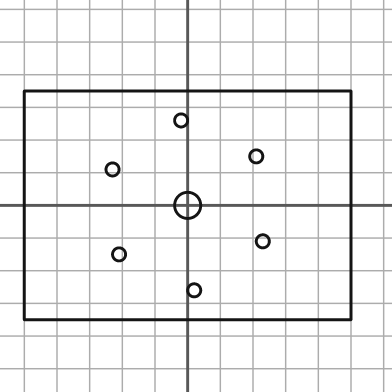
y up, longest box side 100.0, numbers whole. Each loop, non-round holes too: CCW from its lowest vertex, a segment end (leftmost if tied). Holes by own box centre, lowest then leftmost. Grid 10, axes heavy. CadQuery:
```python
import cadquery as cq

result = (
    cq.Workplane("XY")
    .moveTo(-50.0, -35.0)
    .lineTo(50.0, -35.0)
    .lineTo(50.0, 35.0)
    .lineTo(-50.0, 35.0)
    .close()
    .moveTo(2.0, -26.0)
    .circle(2.0)
    .moveTo(-21.0, -15.0)
    .circle(2.0)
    .moveTo(23.0, -11.0)
    .circle(2.0)
    .moveTo(0.0, 0.0)
    .circle(4.0)
    .moveTo(-23.0, 11.0)
    .circle(2.0)
    .moveTo(21.0, 15.0)
    .circle(2.0)
    .moveTo(-2.0, 26.0)
    .circle(2.0)
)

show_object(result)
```